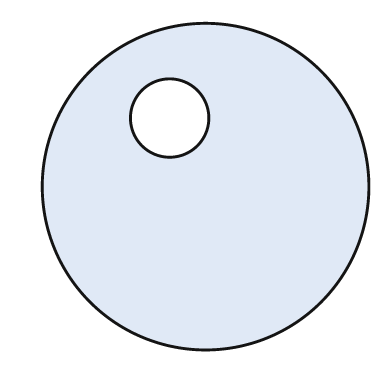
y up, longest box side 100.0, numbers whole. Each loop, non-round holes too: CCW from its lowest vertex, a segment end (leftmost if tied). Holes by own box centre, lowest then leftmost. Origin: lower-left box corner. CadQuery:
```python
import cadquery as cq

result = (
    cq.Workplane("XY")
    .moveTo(50.0, 50.0)
    .circle(50.0)
    .moveTo(39.0, 71.0)
    .circle(12.0)
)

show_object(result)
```